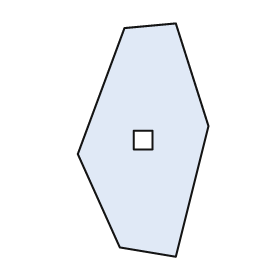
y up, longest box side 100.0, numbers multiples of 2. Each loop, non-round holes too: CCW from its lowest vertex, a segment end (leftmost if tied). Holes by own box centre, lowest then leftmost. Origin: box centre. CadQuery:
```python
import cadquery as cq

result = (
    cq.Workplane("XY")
    .moveTo(14.0, -50.0)
    .lineTo(28.0, 6.0)
    .lineTo(14.0, 50.0)
    .lineTo(-8.0, 48.0)
    .lineTo(-28.0, -6.0)
    .lineTo(-10.0, -46.0)
    .close()
    .moveTo(-4.0, -4.0)
    .lineTo(4.0, -4.0)
    .lineTo(4.0, 4.0)
    .lineTo(-4.0, 4.0)
    .close()
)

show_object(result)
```